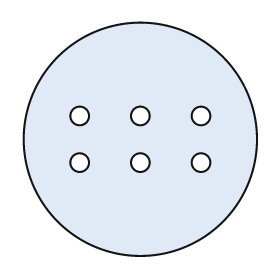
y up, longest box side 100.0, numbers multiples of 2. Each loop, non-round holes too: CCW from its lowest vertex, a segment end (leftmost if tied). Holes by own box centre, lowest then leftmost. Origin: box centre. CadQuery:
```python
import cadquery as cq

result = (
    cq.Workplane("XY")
    .moveTo(0.0, 0.0)
    .circle(50.0)
    .moveTo(-26.0, -10.0)
    .circle(4.0)
    .moveTo(0.0, -10.0)
    .circle(4.0)
    .moveTo(26.0, -10.0)
    .circle(4.0)
    .moveTo(-26.0, 10.0)
    .circle(4.0)
    .moveTo(0.0, 10.0)
    .circle(4.0)
    .moveTo(26.0, 10.0)
    .circle(4.0)
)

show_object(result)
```